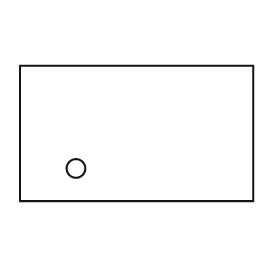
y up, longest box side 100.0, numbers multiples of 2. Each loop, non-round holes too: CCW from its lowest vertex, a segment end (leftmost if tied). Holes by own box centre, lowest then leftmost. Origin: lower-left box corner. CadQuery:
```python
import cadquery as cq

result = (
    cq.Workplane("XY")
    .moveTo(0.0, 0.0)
    .lineTo(100.0, 0.0)
    .lineTo(100.0, 58.0)
    .lineTo(0.0, 58.0)
    .close()
    .moveTo(24.0, 14.0)
    .circle(4.0)
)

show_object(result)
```